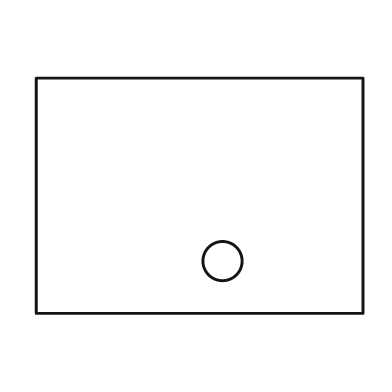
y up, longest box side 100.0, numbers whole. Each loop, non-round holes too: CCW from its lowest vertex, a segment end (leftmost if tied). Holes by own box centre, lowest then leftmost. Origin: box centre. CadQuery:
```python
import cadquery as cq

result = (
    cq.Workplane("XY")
    .moveTo(-50.0, -36.0)
    .lineTo(50.0, -36.0)
    .lineTo(50.0, 36.0)
    .lineTo(-50.0, 36.0)
    .close()
    .moveTo(7.0, -20.0)
    .circle(6.0)
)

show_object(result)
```